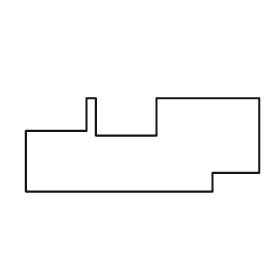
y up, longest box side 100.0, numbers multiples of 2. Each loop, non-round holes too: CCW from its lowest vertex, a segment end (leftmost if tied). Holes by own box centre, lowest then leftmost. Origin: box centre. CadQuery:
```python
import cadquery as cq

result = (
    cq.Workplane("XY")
    .moveTo(-50.0, -20.0)
    .lineTo(30.0, -20.0)
    .lineTo(30.0, -12.0)
    .lineTo(50.0, -12.0)
    .lineTo(50.0, 20.0)
    .lineTo(6.0, 20.0)
    .lineTo(6.0, 4.0)
    .lineTo(-20.0, 4.0)
    .lineTo(-20.0, 20.0)
    .lineTo(-24.0, 20.0)
    .lineTo(-24.0, 6.0)
    .lineTo(-50.0, 6.0)
    .close()
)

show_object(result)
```